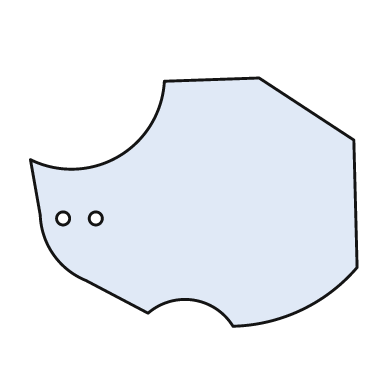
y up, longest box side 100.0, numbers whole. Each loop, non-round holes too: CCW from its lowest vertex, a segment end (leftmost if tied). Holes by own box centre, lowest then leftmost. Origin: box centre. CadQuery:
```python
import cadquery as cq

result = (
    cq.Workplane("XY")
    .moveTo(12.0, -38.0)
    .threePointArc((33.0, -33.0), (50.0, -20.0))
    .lineTo(49.0, 19.0)
    .lineTo(20.0, 38.0)
    .lineTo(-9.0, 37.0)
    .threePointArc((-23.0, 14.0), (-50.0, 13.0))
    .lineTo(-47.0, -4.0)
    .threePointArc((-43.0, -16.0), (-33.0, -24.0))
    .lineTo(-14.0, -34.0)
    .threePointArc((0.0, -30.0), (12.0, -38.0))
    .close()
    .moveTo(-40.0, -5.0)
    .circle(2.0)
    .moveTo(-30.0, -5.0)
    .circle(2.0)
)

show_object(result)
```